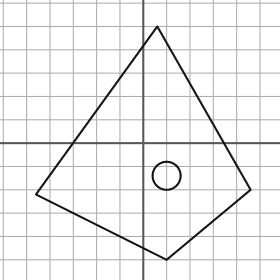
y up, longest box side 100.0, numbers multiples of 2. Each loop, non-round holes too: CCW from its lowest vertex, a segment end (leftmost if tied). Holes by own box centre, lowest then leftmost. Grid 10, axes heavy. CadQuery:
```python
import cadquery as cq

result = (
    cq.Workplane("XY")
    .moveTo(10.0, -50.0)
    .lineTo(46.0, -20.0)
    .lineTo(6.0, 50.0)
    .lineTo(-46.0, -22.0)
    .close()
    .moveTo(10.0, -14.0)
    .circle(6.0)
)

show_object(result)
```